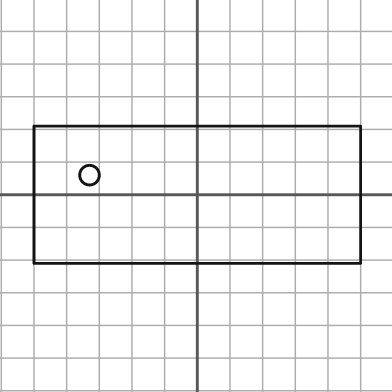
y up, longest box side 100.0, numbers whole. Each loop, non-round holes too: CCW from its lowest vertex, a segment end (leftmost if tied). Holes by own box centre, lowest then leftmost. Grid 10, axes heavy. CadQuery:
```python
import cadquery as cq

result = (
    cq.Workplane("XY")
    .moveTo(-50.0, -21.0)
    .lineTo(50.0, -21.0)
    .lineTo(50.0, 21.0)
    .lineTo(-50.0, 21.0)
    .close()
    .moveTo(-33.0, 6.0)
    .circle(3.0)
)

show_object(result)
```